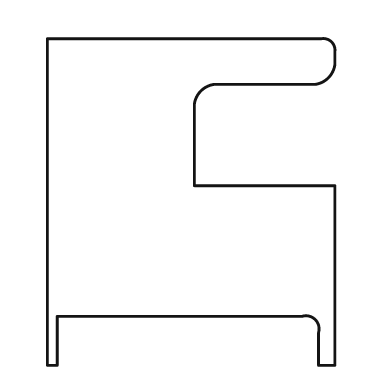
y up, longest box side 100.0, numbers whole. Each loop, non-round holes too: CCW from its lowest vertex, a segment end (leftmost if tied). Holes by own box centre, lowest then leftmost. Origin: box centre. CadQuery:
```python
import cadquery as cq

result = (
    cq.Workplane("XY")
    .moveTo(-44.0, -50.0)
    .lineTo(-41.0, -50.0)
    .lineTo(-41.0, -35.0)
    .lineTo(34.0, -35.0)
    .threePointArc((38.0, -36.0), (39.0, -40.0))
    .lineTo(39.0, -50.0)
    .lineTo(44.0, -50.0)
    .lineTo(44.0, 5.0)
    .lineTo(1.0, 5.0)
    .lineTo(1.0, 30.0)
    .threePointArc((3.0, 34.0), (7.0, 36.0))
    .lineTo(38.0, 36.0)
    .threePointArc((42.0, 38.0), (44.0, 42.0))
    .lineTo(44.0, 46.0)
    .threePointArc((43.0, 49.0), (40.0, 50.0))
    .lineTo(-44.0, 50.0)
    .close()
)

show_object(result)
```